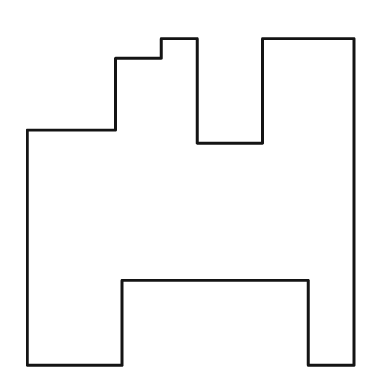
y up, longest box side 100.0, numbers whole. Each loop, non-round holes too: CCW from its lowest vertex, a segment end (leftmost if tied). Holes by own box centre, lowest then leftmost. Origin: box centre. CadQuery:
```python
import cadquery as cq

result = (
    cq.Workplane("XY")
    .moveTo(-50.0, -50.0)
    .lineTo(-21.0, -50.0)
    .lineTo(-21.0, -24.0)
    .lineTo(36.0, -24.0)
    .lineTo(36.0, -50.0)
    .lineTo(50.0, -50.0)
    .lineTo(50.0, 50.0)
    .lineTo(22.0, 50.0)
    .lineTo(22.0, 18.0)
    .lineTo(2.0, 18.0)
    .lineTo(2.0, 50.0)
    .lineTo(-9.0, 50.0)
    .lineTo(-9.0, 44.0)
    .lineTo(-23.0, 44.0)
    .lineTo(-23.0, 22.0)
    .lineTo(-50.0, 22.0)
    .close()
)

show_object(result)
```